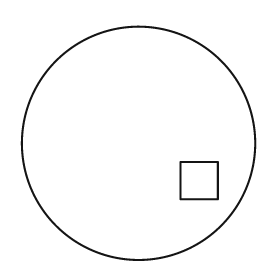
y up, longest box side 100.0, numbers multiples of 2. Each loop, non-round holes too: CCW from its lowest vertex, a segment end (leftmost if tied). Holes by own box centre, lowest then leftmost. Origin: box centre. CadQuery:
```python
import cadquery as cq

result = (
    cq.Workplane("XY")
    .moveTo(0.0, 0.0)
    .circle(50.0)
    .moveTo(18.0, -24.0)
    .lineTo(34.0, -24.0)
    .lineTo(34.0, -8.0)
    .lineTo(18.0, -8.0)
    .close()
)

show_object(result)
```